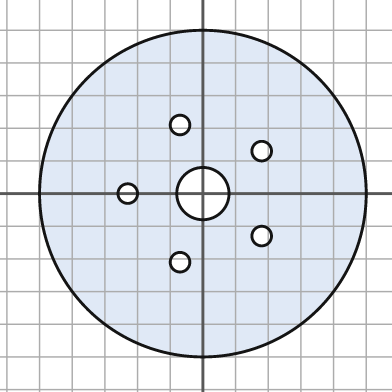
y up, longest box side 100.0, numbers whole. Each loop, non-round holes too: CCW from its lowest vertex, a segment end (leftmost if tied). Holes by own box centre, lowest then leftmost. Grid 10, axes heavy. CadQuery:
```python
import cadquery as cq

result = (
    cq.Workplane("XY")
    .moveTo(0.0, 0.0)
    .circle(50.0)
    .moveTo(-7.0, -21.0)
    .circle(3.0)
    .moveTo(18.0, -13.0)
    .circle(3.0)
    .moveTo(-23.0, 0.0)
    .circle(3.0)
    .moveTo(0.0, 0.0)
    .circle(8.0)
    .moveTo(18.0, 13.0)
    .circle(3.0)
    .moveTo(-7.0, 21.0)
    .circle(3.0)
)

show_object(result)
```